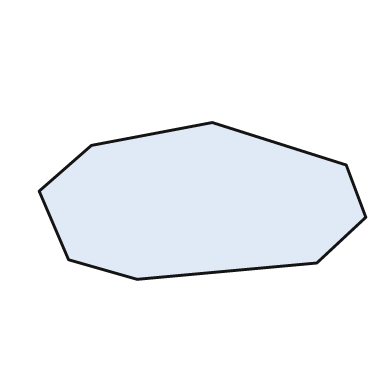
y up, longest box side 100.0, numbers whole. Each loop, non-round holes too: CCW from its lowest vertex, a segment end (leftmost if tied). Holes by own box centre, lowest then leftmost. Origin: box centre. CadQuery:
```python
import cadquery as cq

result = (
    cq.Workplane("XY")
    .moveTo(-20.0, -24.0)
    .lineTo(35.0, -19.0)
    .lineTo(50.0, -5.0)
    .lineTo(44.0, 11.0)
    .lineTo(3.0, 24.0)
    .lineTo(-34.0, 17.0)
    .lineTo(-50.0, 3.0)
    .lineTo(-41.0, -18.0)
    .close()
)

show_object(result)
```